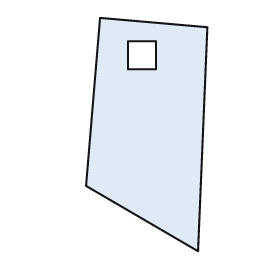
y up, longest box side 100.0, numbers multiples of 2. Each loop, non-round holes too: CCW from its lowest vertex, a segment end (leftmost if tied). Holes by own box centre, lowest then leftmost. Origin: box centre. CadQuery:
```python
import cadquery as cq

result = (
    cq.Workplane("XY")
    .moveTo(22.0, -50.0)
    .lineTo(26.0, 46.0)
    .lineTo(-20.0, 50.0)
    .lineTo(-26.0, -22.0)
    .close()
    .moveTo(-8.0, 28.0)
    .lineTo(4.0, 28.0)
    .lineTo(4.0, 40.0)
    .lineTo(-8.0, 40.0)
    .close()
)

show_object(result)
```